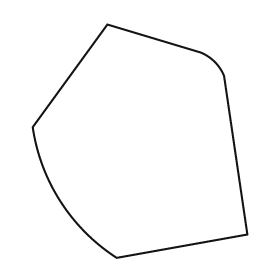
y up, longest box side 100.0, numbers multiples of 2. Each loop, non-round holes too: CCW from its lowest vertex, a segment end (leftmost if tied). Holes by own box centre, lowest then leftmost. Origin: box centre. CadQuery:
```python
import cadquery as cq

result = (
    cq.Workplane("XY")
    .moveTo(-10.0, -50.0)
    .lineTo(46.0, -40.0)
    .lineTo(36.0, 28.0)
    .threePointArc((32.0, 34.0), (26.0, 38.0))
    .lineTo(-14.0, 50.0)
    .lineTo(-46.0, 6.0)
    .threePointArc((-34.0, -26.0), (-10.0, -50.0))
    .close()
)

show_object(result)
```